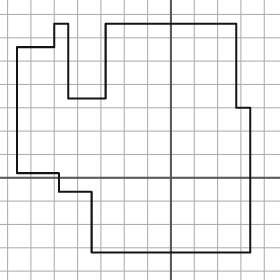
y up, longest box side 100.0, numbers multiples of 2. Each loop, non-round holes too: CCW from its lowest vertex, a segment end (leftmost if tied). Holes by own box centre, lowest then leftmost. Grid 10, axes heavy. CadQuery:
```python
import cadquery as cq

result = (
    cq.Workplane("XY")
    .moveTo(-34.0, -32.0)
    .lineTo(34.0, -32.0)
    .lineTo(34.0, 30.0)
    .lineTo(28.0, 30.0)
    .lineTo(28.0, 66.0)
    .lineTo(-28.0, 66.0)
    .lineTo(-28.0, 34.0)
    .lineTo(-44.0, 34.0)
    .lineTo(-44.0, 66.0)
    .lineTo(-50.0, 66.0)
    .lineTo(-50.0, 56.0)
    .lineTo(-66.0, 56.0)
    .lineTo(-66.0, 2.0)
    .lineTo(-48.0, 2.0)
    .lineTo(-48.0, -6.0)
    .lineTo(-34.0, -6.0)
    .close()
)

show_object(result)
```